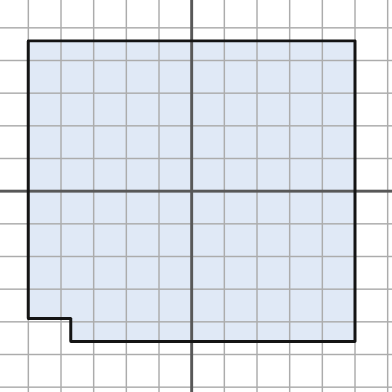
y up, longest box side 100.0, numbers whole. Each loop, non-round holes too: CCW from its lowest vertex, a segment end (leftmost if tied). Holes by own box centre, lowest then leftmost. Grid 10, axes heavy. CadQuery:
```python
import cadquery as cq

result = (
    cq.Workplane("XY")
    .moveTo(-37.0, -46.0)
    .lineTo(50.0, -46.0)
    .lineTo(50.0, 46.0)
    .lineTo(-50.0, 46.0)
    .lineTo(-50.0, -39.0)
    .lineTo(-37.0, -39.0)
    .close()
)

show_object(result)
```